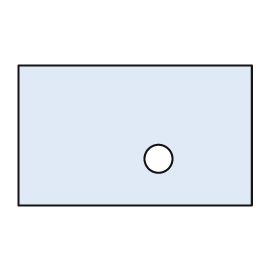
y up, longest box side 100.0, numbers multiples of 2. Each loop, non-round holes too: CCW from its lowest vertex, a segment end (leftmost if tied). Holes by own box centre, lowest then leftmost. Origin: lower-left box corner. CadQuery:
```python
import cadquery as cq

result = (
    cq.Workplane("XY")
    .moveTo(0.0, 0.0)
    .lineTo(100.0, 0.0)
    .lineTo(100.0, 60.0)
    .lineTo(0.0, 60.0)
    .close()
    .moveTo(60.0, 20.0)
    .circle(6.0)
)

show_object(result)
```